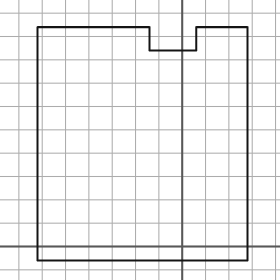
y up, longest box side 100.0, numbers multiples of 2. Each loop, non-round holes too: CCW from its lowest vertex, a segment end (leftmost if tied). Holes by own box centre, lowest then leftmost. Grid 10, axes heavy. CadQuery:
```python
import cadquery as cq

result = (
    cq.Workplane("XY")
    .moveTo(-62.0, -6.0)
    .lineTo(28.0, -6.0)
    .lineTo(28.0, 94.0)
    .lineTo(6.0, 94.0)
    .lineTo(6.0, 84.0)
    .lineTo(-14.0, 84.0)
    .lineTo(-14.0, 94.0)
    .lineTo(-62.0, 94.0)
    .close()
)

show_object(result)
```